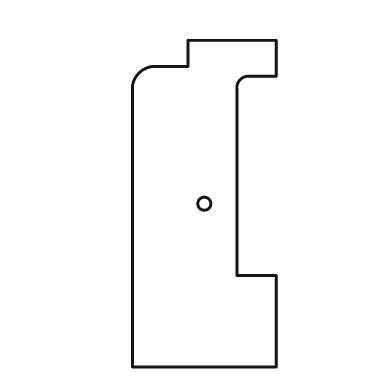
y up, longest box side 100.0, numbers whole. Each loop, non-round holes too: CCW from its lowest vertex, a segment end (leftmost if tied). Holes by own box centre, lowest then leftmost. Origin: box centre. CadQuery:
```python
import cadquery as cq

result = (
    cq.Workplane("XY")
    .moveTo(-22.0, -50.0)
    .lineTo(22.0, -50.0)
    .lineTo(22.0, -22.0)
    .lineTo(10.0, -22.0)
    .lineTo(10.0, 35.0)
    .threePointArc((11.0, 38.0), (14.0, 39.0))
    .lineTo(22.0, 39.0)
    .lineTo(22.0, 50.0)
    .lineTo(-5.0, 50.0)
    .lineTo(-5.0, 42.0)
    .lineTo(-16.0, 42.0)
    .threePointArc((-20.0, 40.0), (-22.0, 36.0))
    .close()
    .moveTo(0.0, 0.0)
    .circle(2.0)
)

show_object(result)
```